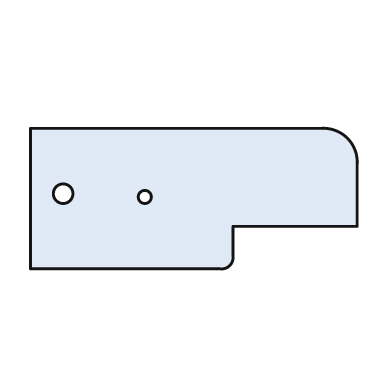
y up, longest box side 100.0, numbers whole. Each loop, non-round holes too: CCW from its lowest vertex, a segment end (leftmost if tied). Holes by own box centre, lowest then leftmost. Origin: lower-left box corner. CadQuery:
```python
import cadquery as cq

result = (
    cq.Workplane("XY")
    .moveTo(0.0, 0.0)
    .lineTo(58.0, 0.0)
    .threePointArc((61.0, 1.0), (62.0, 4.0))
    .lineTo(62.0, 13.0)
    .lineTo(100.0, 13.0)
    .lineTo(100.0, 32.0)
    .threePointArc((97.0, 40.0), (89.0, 43.0))
    .lineTo(0.0, 43.0)
    .close()
    .moveTo(35.0, 22.0)
    .circle(2.0)
    .moveTo(10.0, 23.0)
    .circle(3.0)
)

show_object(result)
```